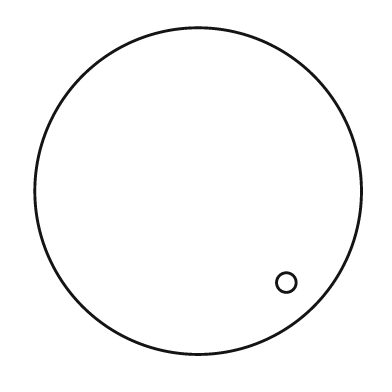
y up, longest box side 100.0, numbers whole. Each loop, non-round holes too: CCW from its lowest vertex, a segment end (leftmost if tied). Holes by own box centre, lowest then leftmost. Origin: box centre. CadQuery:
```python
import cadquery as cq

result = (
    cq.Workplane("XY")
    .moveTo(0.0, 0.0)
    .circle(50.0)
    .moveTo(27.0, -28.0)
    .circle(3.0)
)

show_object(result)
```